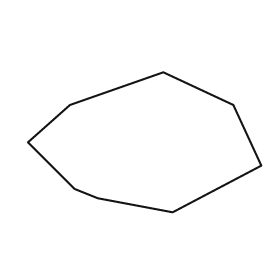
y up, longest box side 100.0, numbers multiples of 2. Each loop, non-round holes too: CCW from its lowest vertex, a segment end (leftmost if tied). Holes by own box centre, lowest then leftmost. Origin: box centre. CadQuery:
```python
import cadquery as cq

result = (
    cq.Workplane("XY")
    .moveTo(12.0, -30.0)
    .lineTo(50.0, -10.0)
    .lineTo(38.0, 16.0)
    .lineTo(8.0, 30.0)
    .lineTo(-32.0, 16.0)
    .lineTo(-50.0, 0.0)
    .lineTo(-30.0, -20.0)
    .lineTo(-20.0, -24.0)
    .close()
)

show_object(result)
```